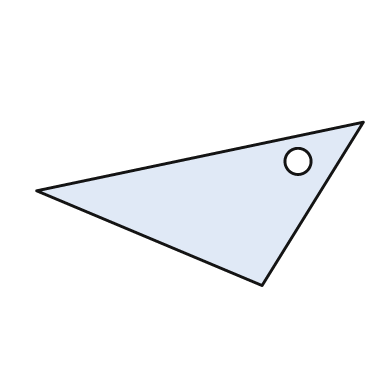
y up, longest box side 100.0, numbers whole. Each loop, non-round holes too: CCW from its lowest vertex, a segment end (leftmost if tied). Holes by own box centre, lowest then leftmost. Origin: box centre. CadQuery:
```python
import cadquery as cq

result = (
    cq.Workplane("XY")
    .moveTo(19.0, -25.0)
    .lineTo(50.0, 25.0)
    .lineTo(-50.0, 4.0)
    .close()
    .moveTo(30.0, 13.0)
    .circle(4.0)
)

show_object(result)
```